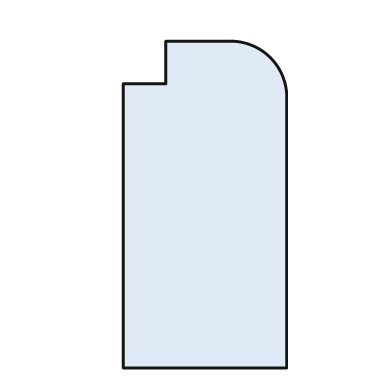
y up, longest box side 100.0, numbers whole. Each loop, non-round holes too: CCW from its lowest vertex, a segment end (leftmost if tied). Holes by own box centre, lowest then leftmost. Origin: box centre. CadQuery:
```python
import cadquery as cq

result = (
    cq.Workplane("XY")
    .moveTo(-25.0, -50.0)
    .lineTo(25.0, -50.0)
    .lineTo(25.0, 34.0)
    .threePointArc((20.0, 45.0), (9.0, 50.0))
    .lineTo(-12.0, 50.0)
    .lineTo(-12.0, 37.0)
    .lineTo(-25.0, 37.0)
    .close()
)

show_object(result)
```